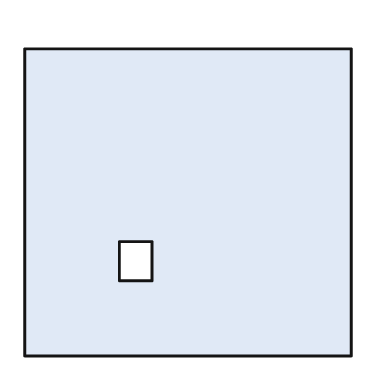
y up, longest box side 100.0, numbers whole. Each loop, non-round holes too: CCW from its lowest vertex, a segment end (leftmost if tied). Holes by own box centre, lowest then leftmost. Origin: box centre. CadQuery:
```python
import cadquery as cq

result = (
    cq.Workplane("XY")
    .moveTo(-50.0, -47.0)
    .lineTo(50.0, -47.0)
    .lineTo(50.0, 47.0)
    .lineTo(-50.0, 47.0)
    .close()
    .moveTo(-21.0, -24.0)
    .lineTo(-11.0, -24.0)
    .lineTo(-11.0, -12.0)
    .lineTo(-21.0, -12.0)
    .close()
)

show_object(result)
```